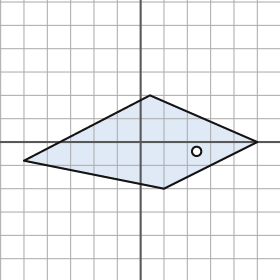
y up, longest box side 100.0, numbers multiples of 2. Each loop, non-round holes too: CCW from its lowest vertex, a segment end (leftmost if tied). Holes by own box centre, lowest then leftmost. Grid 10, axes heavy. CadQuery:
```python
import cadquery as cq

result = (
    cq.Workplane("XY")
    .moveTo(10.0, -20.0)
    .lineTo(50.0, 0.0)
    .lineTo(4.0, 20.0)
    .lineTo(-50.0, -8.0)
    .close()
    .moveTo(24.0, -4.0)
    .circle(2.0)
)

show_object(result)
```